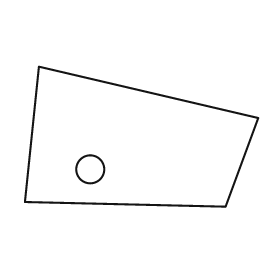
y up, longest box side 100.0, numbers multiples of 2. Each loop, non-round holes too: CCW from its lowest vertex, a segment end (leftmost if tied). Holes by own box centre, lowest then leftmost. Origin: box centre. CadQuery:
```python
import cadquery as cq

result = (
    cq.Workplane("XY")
    .moveTo(36.0, -30.0)
    .lineTo(50.0, 8.0)
    .lineTo(-44.0, 30.0)
    .lineTo(-50.0, -28.0)
    .close()
    .moveTo(-22.0, -14.0)
    .circle(6.0)
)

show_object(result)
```